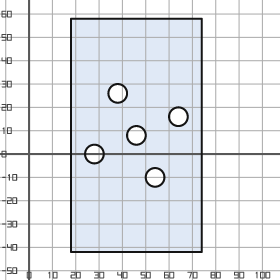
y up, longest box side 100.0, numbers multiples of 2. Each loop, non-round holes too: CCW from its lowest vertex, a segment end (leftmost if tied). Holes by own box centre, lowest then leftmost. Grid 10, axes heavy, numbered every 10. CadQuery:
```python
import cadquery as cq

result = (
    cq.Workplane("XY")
    .moveTo(18.0, -42.0)
    .lineTo(74.0, -42.0)
    .lineTo(74.0, 58.0)
    .lineTo(18.0, 58.0)
    .close()
    .moveTo(54.0, -10.0)
    .circle(4.0)
    .moveTo(28.0, 0.0)
    .circle(4.0)
    .moveTo(46.0, 8.0)
    .circle(4.0)
    .moveTo(64.0, 16.0)
    .circle(4.0)
    .moveTo(38.0, 26.0)
    .circle(4.0)
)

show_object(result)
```